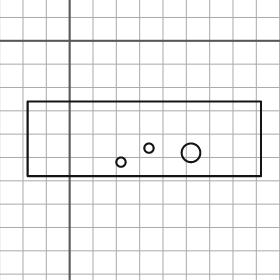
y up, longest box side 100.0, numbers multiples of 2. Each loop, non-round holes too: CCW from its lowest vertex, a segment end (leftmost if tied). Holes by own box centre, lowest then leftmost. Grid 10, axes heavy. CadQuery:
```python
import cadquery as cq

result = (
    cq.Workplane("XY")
    .moveTo(-18.0, -58.0)
    .lineTo(82.0, -58.0)
    .lineTo(82.0, -26.0)
    .lineTo(-18.0, -26.0)
    .close()
    .moveTo(22.0, -52.0)
    .circle(2.0)
    .moveTo(52.0, -48.0)
    .circle(4.0)
    .moveTo(34.0, -46.0)
    .circle(2.0)
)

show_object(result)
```